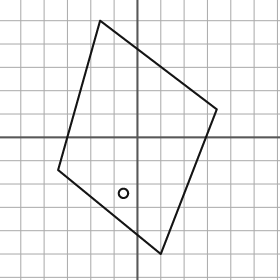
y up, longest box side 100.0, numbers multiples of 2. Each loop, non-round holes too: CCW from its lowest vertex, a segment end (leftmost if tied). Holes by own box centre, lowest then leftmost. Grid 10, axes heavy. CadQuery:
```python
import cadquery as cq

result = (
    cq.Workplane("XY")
    .moveTo(10.0, -50.0)
    .lineTo(34.0, 12.0)
    .lineTo(-16.0, 50.0)
    .lineTo(-34.0, -14.0)
    .close()
    .moveTo(-6.0, -24.0)
    .circle(2.0)
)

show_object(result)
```